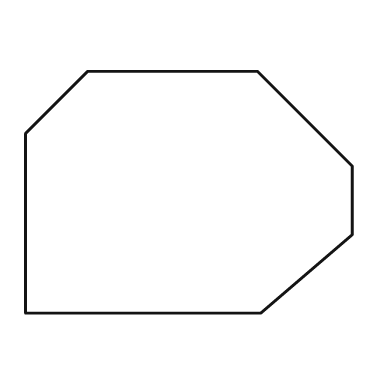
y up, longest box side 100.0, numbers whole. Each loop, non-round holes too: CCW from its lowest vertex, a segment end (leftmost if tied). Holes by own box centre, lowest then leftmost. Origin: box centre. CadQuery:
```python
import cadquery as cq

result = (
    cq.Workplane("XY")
    .moveTo(-50.0, -37.0)
    .lineTo(22.0, -37.0)
    .lineTo(50.0, -13.0)
    .lineTo(50.0, 8.0)
    .lineTo(21.0, 37.0)
    .lineTo(-31.0, 37.0)
    .lineTo(-50.0, 18.0)
    .close()
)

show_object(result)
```